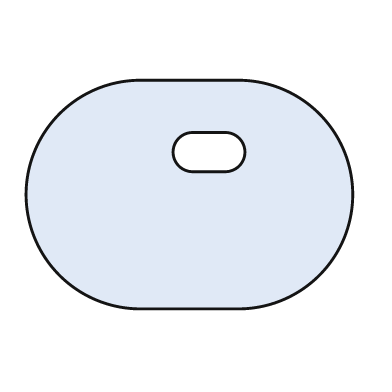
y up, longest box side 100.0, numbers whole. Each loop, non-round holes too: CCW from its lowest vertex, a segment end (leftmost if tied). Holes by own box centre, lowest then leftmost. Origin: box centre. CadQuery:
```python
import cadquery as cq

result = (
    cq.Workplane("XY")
    .moveTo(-15.0, -35.0)
    .lineTo(15.0, -35.0)
    .threePointArc((50.0, 0.0), (15.0, 35.0))
    .lineTo(-15.0, 35.0)
    .threePointArc((-50.0, 0.0), (-15.0, -35.0))
    .close()
    .moveTo(1.0, 7.0)
    .lineTo(11.0, 7.0)
    .threePointArc((17.0, 13.0), (11.0, 19.0))
    .lineTo(1.0, 19.0)
    .threePointArc((-5.0, 13.0), (1.0, 7.0))
    .close()
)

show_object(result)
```